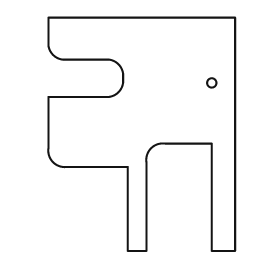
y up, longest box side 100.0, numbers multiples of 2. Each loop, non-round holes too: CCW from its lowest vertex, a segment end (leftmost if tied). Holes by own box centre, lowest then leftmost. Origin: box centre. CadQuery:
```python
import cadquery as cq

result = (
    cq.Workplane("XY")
    .moveTo(-6.0, -50.0)
    .lineTo(2.0, -50.0)
    .lineTo(2.0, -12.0)
    .threePointArc((4.0, -6.0), (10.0, -4.0))
    .lineTo(30.0, -4.0)
    .lineTo(30.0, -50.0)
    .lineTo(40.0, -50.0)
    .lineTo(40.0, 50.0)
    .lineTo(-40.0, 50.0)
    .lineTo(-40.0, 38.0)
    .threePointArc((-38.0, 34.0), (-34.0, 32.0))
    .lineTo(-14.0, 32.0)
    .threePointArc((-10.0, 30.0), (-8.0, 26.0))
    .lineTo(-8.0, 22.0)
    .threePointArc((-10.0, 18.0), (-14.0, 16.0))
    .lineTo(-40.0, 16.0)
    .lineTo(-40.0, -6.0)
    .threePointArc((-38.0, -12.0), (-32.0, -14.0))
    .lineTo(-6.0, -14.0)
    .close()
    .moveTo(30.0, 22.0)
    .circle(2.0)
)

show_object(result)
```